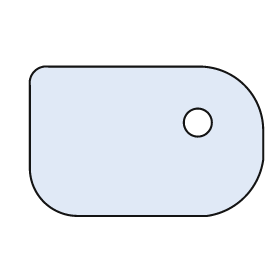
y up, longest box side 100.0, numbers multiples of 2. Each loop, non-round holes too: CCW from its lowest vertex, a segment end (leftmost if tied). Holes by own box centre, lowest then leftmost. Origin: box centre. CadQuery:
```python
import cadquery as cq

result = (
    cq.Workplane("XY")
    .moveTo(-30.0, -32.0)
    .lineTo(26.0, -32.0)
    .threePointArc((42.0, -24.0), (50.0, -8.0))
    .lineTo(50.0, 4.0)
    .threePointArc((42.0, 24.0), (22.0, 32.0))
    .lineTo(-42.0, 32.0)
    .threePointArc((-48.0, 30.0), (-50.0, 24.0))
    .lineTo(-50.0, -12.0)
    .threePointArc((-44.0, -26.0), (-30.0, -32.0))
    .close()
    .moveTo(22.0, 8.0)
    .circle(6.0)
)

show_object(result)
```